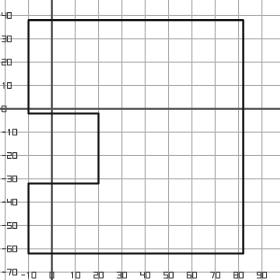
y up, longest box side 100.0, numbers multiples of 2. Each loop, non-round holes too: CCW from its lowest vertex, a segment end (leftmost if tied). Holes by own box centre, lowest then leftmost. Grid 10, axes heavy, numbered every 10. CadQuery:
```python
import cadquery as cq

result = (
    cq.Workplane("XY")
    .moveTo(-10.0, -62.0)
    .lineTo(82.0, -62.0)
    .lineTo(82.0, 38.0)
    .lineTo(-10.0, 38.0)
    .lineTo(-10.0, -2.0)
    .lineTo(20.0, -2.0)
    .lineTo(20.0, -32.0)
    .lineTo(-10.0, -32.0)
    .close()
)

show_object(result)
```